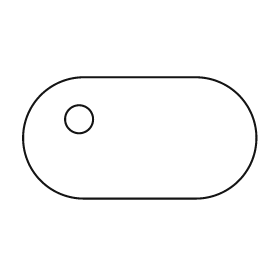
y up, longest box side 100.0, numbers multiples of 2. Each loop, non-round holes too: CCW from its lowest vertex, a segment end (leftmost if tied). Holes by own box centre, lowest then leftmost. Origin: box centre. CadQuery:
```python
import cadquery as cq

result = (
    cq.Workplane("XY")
    .moveTo(-24.0, -26.0)
    .lineTo(24.0, -26.0)
    .threePointArc((50.0, 0.0), (24.0, 26.0))
    .lineTo(-24.0, 26.0)
    .threePointArc((-50.0, 0.0), (-24.0, -26.0))
    .close()
    .moveTo(-26.0, 8.0)
    .circle(6.0)
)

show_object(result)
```